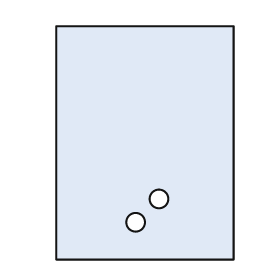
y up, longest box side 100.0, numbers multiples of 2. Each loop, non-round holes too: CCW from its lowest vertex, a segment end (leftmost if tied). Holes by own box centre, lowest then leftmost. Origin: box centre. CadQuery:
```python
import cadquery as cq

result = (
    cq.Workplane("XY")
    .moveTo(-38.0, -50.0)
    .lineTo(38.0, -50.0)
    .lineTo(38.0, 50.0)
    .lineTo(-38.0, 50.0)
    .close()
    .moveTo(-4.0, -34.0)
    .circle(4.0)
    .moveTo(6.0, -24.0)
    .circle(4.0)
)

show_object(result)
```